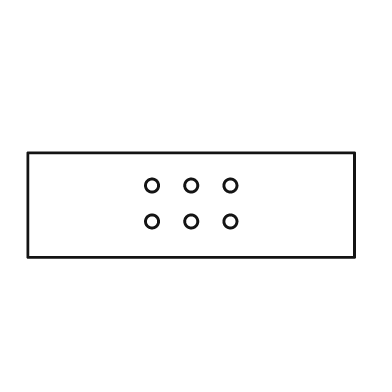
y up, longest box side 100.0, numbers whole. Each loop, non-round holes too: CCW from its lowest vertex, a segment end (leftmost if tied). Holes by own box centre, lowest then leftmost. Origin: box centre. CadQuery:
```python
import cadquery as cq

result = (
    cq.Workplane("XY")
    .moveTo(-50.0, -16.0)
    .lineTo(50.0, -16.0)
    .lineTo(50.0, 16.0)
    .lineTo(-50.0, 16.0)
    .close()
    .moveTo(-12.0, -5.0)
    .circle(2.0)
    .moveTo(0.0, -5.0)
    .circle(2.0)
    .moveTo(12.0, -5.0)
    .circle(2.0)
    .moveTo(-12.0, 6.0)
    .circle(2.0)
    .moveTo(0.0, 6.0)
    .circle(2.0)
    .moveTo(12.0, 6.0)
    .circle(2.0)
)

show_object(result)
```